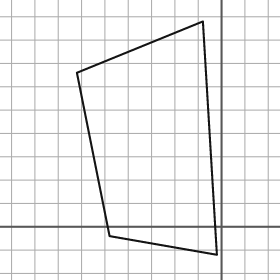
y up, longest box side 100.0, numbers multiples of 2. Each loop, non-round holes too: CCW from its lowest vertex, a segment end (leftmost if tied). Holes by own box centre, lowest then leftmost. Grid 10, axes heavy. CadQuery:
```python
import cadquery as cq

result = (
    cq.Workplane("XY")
    .moveTo(-2.0, -12.0)
    .lineTo(-8.0, 88.0)
    .lineTo(-62.0, 66.0)
    .lineTo(-48.0, -4.0)
    .close()
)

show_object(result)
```